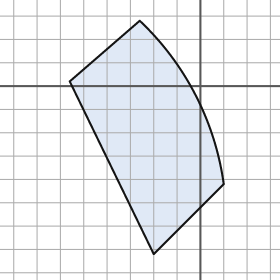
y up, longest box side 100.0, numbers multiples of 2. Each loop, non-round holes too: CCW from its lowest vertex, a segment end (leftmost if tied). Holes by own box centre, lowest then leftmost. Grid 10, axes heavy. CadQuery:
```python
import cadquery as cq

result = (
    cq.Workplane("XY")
    .moveTo(-20.0, -72.0)
    .lineTo(10.0, -42.0)
    .threePointArc((-2.0, -4.0), (-26.0, 28.0))
    .lineTo(-56.0, 2.0)
    .close()
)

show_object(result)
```